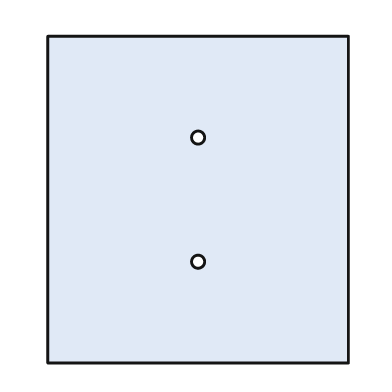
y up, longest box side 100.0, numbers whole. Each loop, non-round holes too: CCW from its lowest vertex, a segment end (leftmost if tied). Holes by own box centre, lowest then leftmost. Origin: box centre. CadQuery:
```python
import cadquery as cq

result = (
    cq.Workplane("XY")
    .moveTo(-46.0, -50.0)
    .lineTo(46.0, -50.0)
    .lineTo(46.0, 50.0)
    .lineTo(-46.0, 50.0)
    .close()
    .moveTo(0.0, -19.0)
    .circle(2.0)
    .moveTo(0.0, 19.0)
    .circle(2.0)
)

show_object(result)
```